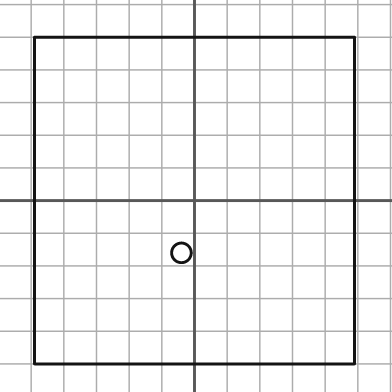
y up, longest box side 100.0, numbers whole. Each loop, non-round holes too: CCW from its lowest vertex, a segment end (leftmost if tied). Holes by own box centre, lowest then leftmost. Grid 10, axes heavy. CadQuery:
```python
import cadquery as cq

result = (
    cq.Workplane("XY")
    .moveTo(-49.0, -50.0)
    .lineTo(49.0, -50.0)
    .lineTo(49.0, 50.0)
    .lineTo(-49.0, 50.0)
    .close()
    .moveTo(-4.0, -16.0)
    .circle(3.0)
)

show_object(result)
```